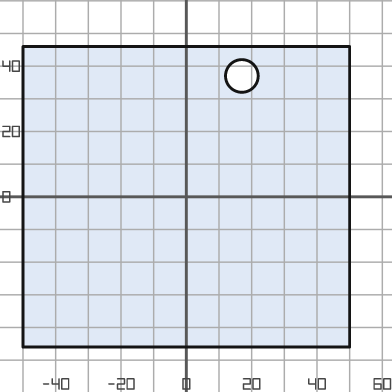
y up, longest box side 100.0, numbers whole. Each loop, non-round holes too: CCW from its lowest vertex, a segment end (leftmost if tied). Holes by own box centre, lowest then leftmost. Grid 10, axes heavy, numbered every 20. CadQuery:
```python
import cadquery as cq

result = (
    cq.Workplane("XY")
    .moveTo(-50.0, -46.0)
    .lineTo(50.0, -46.0)
    .lineTo(50.0, 46.0)
    .lineTo(-50.0, 46.0)
    .close()
    .moveTo(17.0, 37.0)
    .circle(5.0)
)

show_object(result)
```